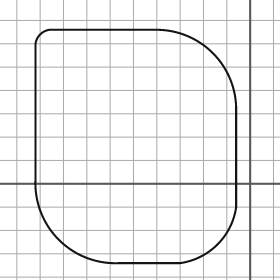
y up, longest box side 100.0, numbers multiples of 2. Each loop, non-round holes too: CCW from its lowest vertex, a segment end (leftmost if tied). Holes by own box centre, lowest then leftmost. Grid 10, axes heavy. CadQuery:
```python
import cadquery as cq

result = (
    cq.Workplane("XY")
    .moveTo(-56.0, -34.0)
    .lineTo(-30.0, -34.0)
    .threePointArc((-14.0, -26.0), (-6.0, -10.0))
    .lineTo(-6.0, 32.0)
    .threePointArc((-16.0, 56.0), (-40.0, 66.0))
    .lineTo(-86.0, 66.0)
    .threePointArc((-90.0, 64.0), (-92.0, 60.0))
    .lineTo(-92.0, 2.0)
    .threePointArc((-82.0, -24.0), (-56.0, -34.0))
    .close()
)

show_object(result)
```